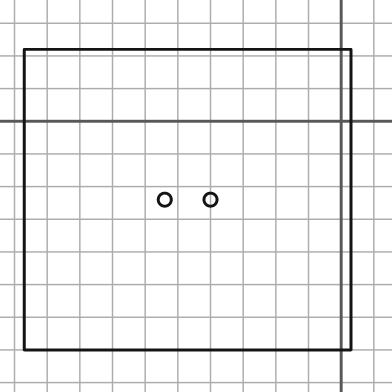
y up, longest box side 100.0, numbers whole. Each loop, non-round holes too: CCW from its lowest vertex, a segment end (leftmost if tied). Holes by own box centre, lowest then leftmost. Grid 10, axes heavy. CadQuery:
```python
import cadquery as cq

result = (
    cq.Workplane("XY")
    .moveTo(-97.0, -70.0)
    .lineTo(3.0, -70.0)
    .lineTo(3.0, 22.0)
    .lineTo(-97.0, 22.0)
    .close()
    .moveTo(-54.0, -24.0)
    .circle(2.0)
    .moveTo(-40.0, -24.0)
    .circle(2.0)
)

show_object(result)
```